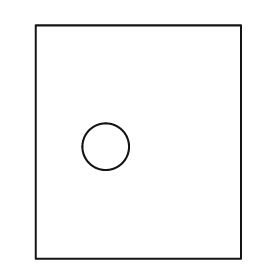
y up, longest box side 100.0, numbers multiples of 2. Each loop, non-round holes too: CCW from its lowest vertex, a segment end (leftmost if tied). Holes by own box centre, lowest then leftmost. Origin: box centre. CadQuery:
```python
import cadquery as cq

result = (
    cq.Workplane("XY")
    .moveTo(-44.0, -50.0)
    .lineTo(44.0, -50.0)
    .lineTo(44.0, 50.0)
    .lineTo(-44.0, 50.0)
    .close()
    .moveTo(-14.0, -2.0)
    .circle(10.0)
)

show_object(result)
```